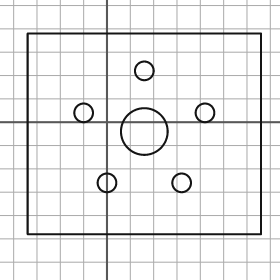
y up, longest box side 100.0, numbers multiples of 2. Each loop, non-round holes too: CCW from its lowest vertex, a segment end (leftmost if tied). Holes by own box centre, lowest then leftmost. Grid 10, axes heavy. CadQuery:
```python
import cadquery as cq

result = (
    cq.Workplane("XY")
    .moveTo(-34.0, -48.0)
    .lineTo(66.0, -48.0)
    .lineTo(66.0, 38.0)
    .lineTo(-34.0, 38.0)
    .close()
    .moveTo(0.0, -26.0)
    .circle(4.0)
    .moveTo(32.0, -26.0)
    .circle(4.0)
    .moveTo(16.0, -4.0)
    .circle(10.0)
    .moveTo(-10.0, 4.0)
    .circle(4.0)
    .moveTo(42.0, 4.0)
    .circle(4.0)
    .moveTo(16.0, 22.0)
    .circle(4.0)
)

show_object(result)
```